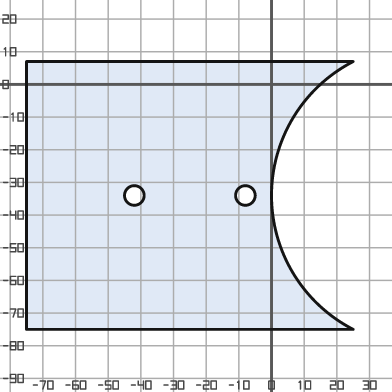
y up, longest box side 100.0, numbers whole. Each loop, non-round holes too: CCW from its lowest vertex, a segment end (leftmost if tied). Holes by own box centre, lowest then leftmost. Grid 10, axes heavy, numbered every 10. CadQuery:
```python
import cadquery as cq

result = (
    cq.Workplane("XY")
    .moveTo(-75.0, -75.0)
    .lineTo(25.0, -75.0)
    .threePointArc((0.0, -34.0), (25.0, 7.0))
    .lineTo(-75.0, 7.0)
    .close()
    .moveTo(-42.0, -34.0)
    .circle(3.0)
    .moveTo(-8.0, -34.0)
    .circle(3.0)
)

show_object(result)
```